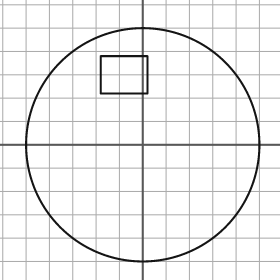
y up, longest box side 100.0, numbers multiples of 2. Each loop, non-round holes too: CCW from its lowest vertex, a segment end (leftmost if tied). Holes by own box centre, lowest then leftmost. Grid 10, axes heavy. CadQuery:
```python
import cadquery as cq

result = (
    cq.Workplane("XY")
    .moveTo(0.0, 0.0)
    .circle(50.0)
    .moveTo(-18.0, 22.0)
    .lineTo(2.0, 22.0)
    .lineTo(2.0, 38.0)
    .lineTo(-18.0, 38.0)
    .close()
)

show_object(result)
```